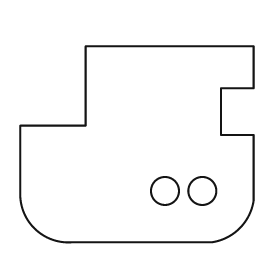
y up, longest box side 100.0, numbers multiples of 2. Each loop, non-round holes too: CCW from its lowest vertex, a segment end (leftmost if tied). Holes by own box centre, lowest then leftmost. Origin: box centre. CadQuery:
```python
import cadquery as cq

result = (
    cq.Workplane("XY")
    .moveTo(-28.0, -42.0)
    .lineTo(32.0, -42.0)
    .threePointArc((44.0, -36.0), (50.0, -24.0))
    .lineTo(50.0, 4.0)
    .lineTo(36.0, 4.0)
    .lineTo(36.0, 24.0)
    .lineTo(50.0, 24.0)
    .lineTo(50.0, 42.0)
    .lineTo(-22.0, 42.0)
    .lineTo(-22.0, 8.0)
    .lineTo(-50.0, 8.0)
    .lineTo(-50.0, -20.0)
    .threePointArc((-44.0, -36.0), (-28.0, -42.0))
    .close()
    .moveTo(12.0, -20.0)
    .circle(6.0)
    .moveTo(28.0, -20.0)
    .circle(6.0)
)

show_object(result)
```